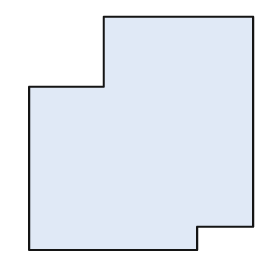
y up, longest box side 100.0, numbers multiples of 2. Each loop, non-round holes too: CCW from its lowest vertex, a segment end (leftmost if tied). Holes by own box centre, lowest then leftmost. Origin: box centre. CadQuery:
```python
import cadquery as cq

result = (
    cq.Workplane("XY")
    .moveTo(-48.0, -50.0)
    .lineTo(24.0, -50.0)
    .lineTo(24.0, -40.0)
    .lineTo(48.0, -40.0)
    .lineTo(48.0, 50.0)
    .lineTo(-16.0, 50.0)
    .lineTo(-16.0, 20.0)
    .lineTo(-48.0, 20.0)
    .close()
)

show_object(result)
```